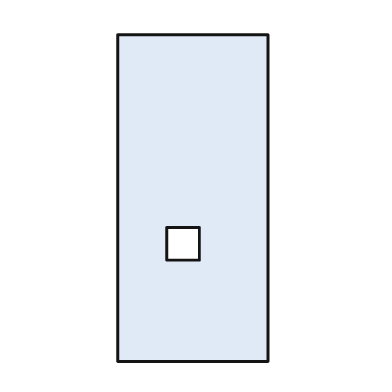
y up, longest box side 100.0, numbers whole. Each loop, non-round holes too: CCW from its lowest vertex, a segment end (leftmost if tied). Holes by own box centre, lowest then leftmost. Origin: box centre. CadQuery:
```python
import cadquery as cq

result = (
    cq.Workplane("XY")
    .moveTo(-23.0, -50.0)
    .lineTo(23.0, -50.0)
    .lineTo(23.0, 50.0)
    .lineTo(-23.0, 50.0)
    .close()
    .moveTo(-8.0, -19.0)
    .lineTo(2.0, -19.0)
    .lineTo(2.0, -9.0)
    .lineTo(-8.0, -9.0)
    .close()
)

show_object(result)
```